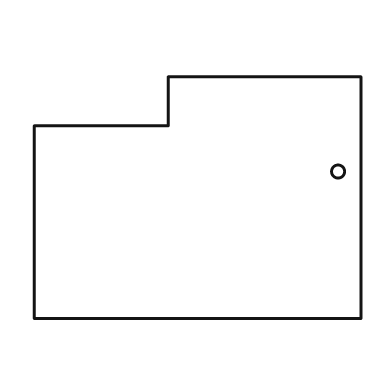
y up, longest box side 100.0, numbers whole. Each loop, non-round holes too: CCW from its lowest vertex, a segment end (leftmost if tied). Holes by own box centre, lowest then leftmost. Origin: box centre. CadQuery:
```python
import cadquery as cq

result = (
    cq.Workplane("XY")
    .moveTo(-50.0, -37.0)
    .lineTo(50.0, -37.0)
    .lineTo(50.0, 37.0)
    .lineTo(-9.0, 37.0)
    .lineTo(-9.0, 22.0)
    .lineTo(-50.0, 22.0)
    .close()
    .moveTo(43.0, 8.0)
    .circle(2.0)
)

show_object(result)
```